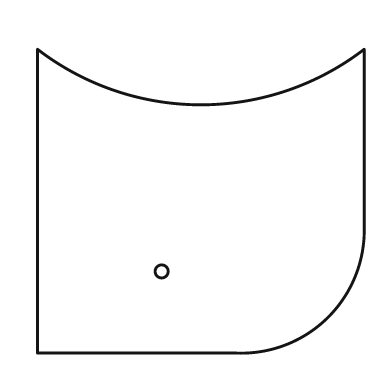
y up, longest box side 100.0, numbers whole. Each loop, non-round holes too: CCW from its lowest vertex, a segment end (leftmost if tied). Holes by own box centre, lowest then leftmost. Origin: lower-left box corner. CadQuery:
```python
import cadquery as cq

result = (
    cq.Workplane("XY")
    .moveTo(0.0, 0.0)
    .lineTo(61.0, 0.0)
    .threePointArc((89.0, 11.0), (100.0, 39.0))
    .lineTo(100.0, 93.0)
    .threePointArc((50.0, 76.0), (0.0, 93.0))
    .close()
    .moveTo(38.0, 25.0)
    .circle(2.0)
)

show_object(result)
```